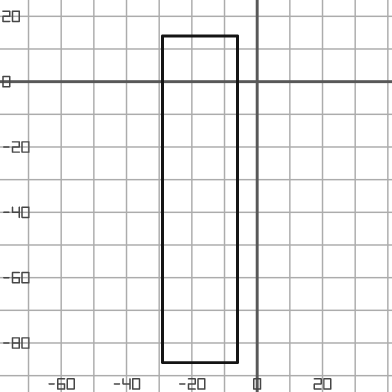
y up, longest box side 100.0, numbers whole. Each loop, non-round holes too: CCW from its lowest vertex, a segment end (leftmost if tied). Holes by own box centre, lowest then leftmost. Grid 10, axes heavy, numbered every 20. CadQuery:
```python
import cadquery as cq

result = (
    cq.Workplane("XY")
    .moveTo(-29.0, -86.0)
    .lineTo(-6.0, -86.0)
    .lineTo(-6.0, 14.0)
    .lineTo(-29.0, 14.0)
    .close()
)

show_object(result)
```